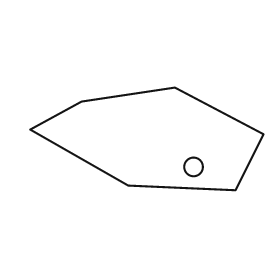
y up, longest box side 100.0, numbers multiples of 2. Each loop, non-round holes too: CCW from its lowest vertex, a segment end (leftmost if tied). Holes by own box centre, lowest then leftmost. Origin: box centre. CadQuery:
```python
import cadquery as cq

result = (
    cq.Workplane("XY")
    .moveTo(38.0, -22.0)
    .lineTo(50.0, 2.0)
    .lineTo(12.0, 22.0)
    .lineTo(-28.0, 16.0)
    .lineTo(-50.0, 4.0)
    .lineTo(-8.0, -20.0)
    .close()
    .moveTo(20.0, -12.0)
    .circle(4.0)
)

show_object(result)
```